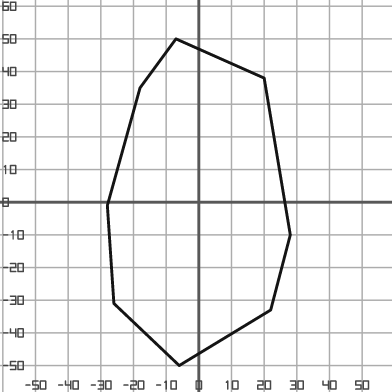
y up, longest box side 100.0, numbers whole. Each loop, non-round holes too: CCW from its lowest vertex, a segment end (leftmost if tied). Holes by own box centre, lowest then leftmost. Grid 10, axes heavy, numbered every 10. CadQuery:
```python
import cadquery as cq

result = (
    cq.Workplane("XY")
    .moveTo(-6.0, -50.0)
    .lineTo(22.0, -33.0)
    .lineTo(28.0, -10.0)
    .lineTo(20.0, 38.0)
    .lineTo(-7.0, 50.0)
    .lineTo(-18.0, 35.0)
    .lineTo(-28.0, -1.0)
    .lineTo(-26.0, -31.0)
    .close()
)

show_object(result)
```